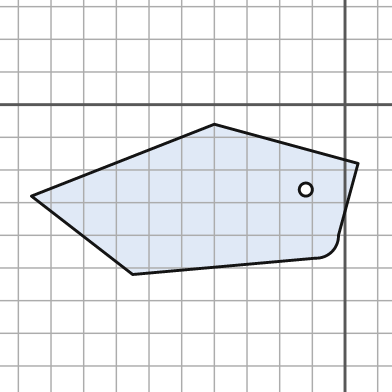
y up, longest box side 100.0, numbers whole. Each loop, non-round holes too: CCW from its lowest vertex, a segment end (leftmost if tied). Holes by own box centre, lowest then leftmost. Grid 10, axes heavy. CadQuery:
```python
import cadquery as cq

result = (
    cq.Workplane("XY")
    .moveTo(-65.0, -52.0)
    .lineTo(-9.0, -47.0)
    .threePointArc((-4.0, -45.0), (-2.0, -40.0))
    .lineTo(4.0, -18.0)
    .lineTo(-40.0, -6.0)
    .lineTo(-96.0, -28.0)
    .close()
    .moveTo(-12.0, -26.0)
    .circle(2.0)
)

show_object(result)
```